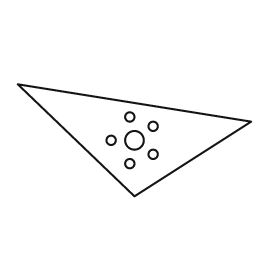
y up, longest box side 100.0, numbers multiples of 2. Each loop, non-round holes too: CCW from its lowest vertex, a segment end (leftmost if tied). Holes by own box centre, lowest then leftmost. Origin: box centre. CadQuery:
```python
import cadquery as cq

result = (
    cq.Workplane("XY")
    .moveTo(0.0, -24.0)
    .lineTo(50.0, 8.0)
    .lineTo(-50.0, 24.0)
    .close()
    .moveTo(-2.0, -10.0)
    .circle(2.0)
    .moveTo(8.0, -6.0)
    .circle(2.0)
    .moveTo(-10.0, 0.0)
    .circle(2.0)
    .moveTo(0.0, 0.0)
    .circle(4.0)
    .moveTo(8.0, 6.0)
    .circle(2.0)
    .moveTo(-2.0, 10.0)
    .circle(2.0)
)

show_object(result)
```